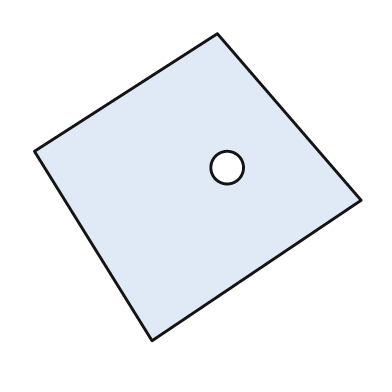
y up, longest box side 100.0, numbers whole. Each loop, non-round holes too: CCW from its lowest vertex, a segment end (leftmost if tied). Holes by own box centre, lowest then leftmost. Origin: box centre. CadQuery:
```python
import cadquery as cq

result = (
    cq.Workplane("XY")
    .moveTo(-14.0, -47.0)
    .lineTo(50.0, -4.0)
    .lineTo(6.0, 47.0)
    .lineTo(-50.0, 11.0)
    .close()
    .moveTo(9.0, 6.0)
    .circle(5.0)
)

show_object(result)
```